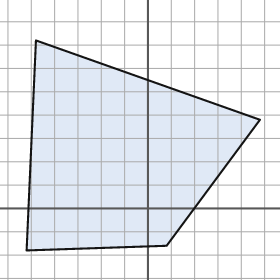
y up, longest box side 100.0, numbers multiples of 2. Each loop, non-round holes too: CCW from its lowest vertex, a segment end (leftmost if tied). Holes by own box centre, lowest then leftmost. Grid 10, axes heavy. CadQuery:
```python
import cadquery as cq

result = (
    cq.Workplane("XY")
    .moveTo(-52.0, -18.0)
    .lineTo(8.0, -16.0)
    .lineTo(48.0, 38.0)
    .lineTo(-48.0, 72.0)
    .close()
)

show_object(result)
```